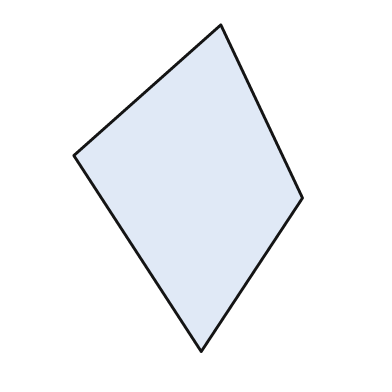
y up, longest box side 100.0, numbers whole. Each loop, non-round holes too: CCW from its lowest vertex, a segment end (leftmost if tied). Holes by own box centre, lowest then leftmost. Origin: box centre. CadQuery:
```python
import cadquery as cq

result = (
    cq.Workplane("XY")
    .moveTo(4.0, -50.0)
    .lineTo(35.0, -3.0)
    .lineTo(10.0, 50.0)
    .lineTo(-35.0, 10.0)
    .close()
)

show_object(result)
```